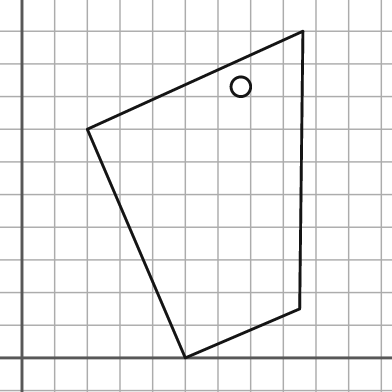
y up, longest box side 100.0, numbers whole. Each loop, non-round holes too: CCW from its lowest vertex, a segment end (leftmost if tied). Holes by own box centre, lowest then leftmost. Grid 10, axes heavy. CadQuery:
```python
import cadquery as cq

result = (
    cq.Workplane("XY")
    .moveTo(50.0, 0.0)
    .lineTo(85.0, 15.0)
    .lineTo(86.0, 100.0)
    .lineTo(20.0, 70.0)
    .close()
    .moveTo(67.0, 83.0)
    .circle(3.0)
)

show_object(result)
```